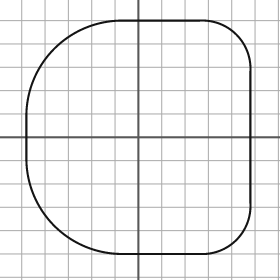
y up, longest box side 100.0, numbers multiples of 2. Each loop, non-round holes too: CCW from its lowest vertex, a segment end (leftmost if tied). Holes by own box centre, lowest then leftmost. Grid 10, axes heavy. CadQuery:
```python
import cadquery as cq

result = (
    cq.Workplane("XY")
    .moveTo(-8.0, -50.0)
    .lineTo(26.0, -50.0)
    .threePointArc((42.0, -44.0), (48.0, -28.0))
    .lineTo(48.0, 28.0)
    .threePointArc((42.0, 44.0), (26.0, 50.0))
    .lineTo(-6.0, 50.0)
    .threePointArc((-36.0, 38.0), (-48.0, 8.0))
    .lineTo(-48.0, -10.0)
    .threePointArc((-36.0, -38.0), (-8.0, -50.0))
    .close()
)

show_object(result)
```